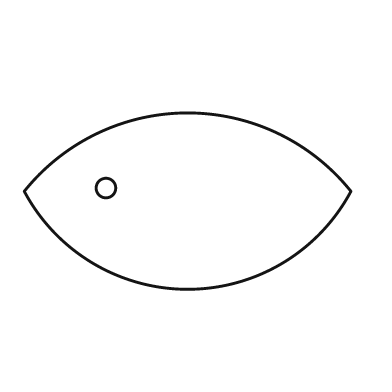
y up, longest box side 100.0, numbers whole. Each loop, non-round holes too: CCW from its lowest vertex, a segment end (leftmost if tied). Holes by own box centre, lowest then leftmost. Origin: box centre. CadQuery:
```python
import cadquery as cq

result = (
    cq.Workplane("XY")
    .moveTo(-50.0, 3.0)
    .threePointArc((0.0, -27.0), (50.0, 3.0))
    .threePointArc((0.0, 27.0), (-50.0, 3.0))
    .close()
    .moveTo(-25.0, 4.0)
    .circle(3.0)
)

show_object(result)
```